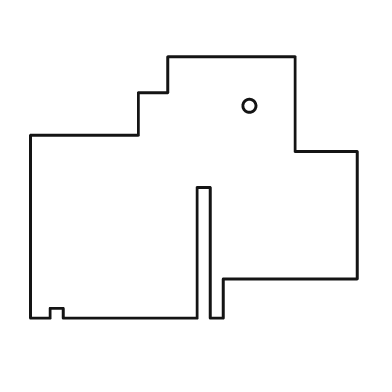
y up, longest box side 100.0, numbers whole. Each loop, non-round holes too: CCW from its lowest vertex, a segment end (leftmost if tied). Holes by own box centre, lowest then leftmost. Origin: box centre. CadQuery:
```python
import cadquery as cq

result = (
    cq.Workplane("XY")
    .moveTo(-50.0, -40.0)
    .lineTo(-44.0, -40.0)
    .lineTo(-44.0, -37.0)
    .lineTo(-40.0, -37.0)
    .lineTo(-40.0, -40.0)
    .lineTo(1.0, -40.0)
    .lineTo(1.0, 0.0)
    .lineTo(5.0, 0.0)
    .lineTo(5.0, -40.0)
    .lineTo(9.0, -40.0)
    .lineTo(9.0, -28.0)
    .lineTo(50.0, -28.0)
    .lineTo(50.0, 11.0)
    .lineTo(31.0, 11.0)
    .lineTo(31.0, 40.0)
    .lineTo(-8.0, 40.0)
    .lineTo(-8.0, 29.0)
    .lineTo(-17.0, 29.0)
    .lineTo(-17.0, 16.0)
    .lineTo(-50.0, 16.0)
    .close()
    .moveTo(17.0, 25.0)
    .circle(2.0)
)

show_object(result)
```